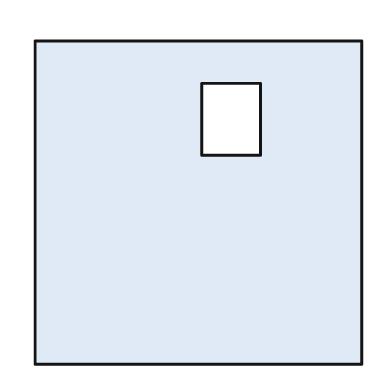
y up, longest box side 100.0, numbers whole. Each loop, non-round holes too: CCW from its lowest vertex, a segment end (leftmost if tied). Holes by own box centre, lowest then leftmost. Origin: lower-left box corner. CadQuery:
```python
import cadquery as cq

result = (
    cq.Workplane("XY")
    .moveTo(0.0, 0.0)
    .lineTo(100.0, 0.0)
    .lineTo(100.0, 99.0)
    .lineTo(0.0, 99.0)
    .close()
    .moveTo(51.0, 64.0)
    .lineTo(69.0, 64.0)
    .lineTo(69.0, 86.0)
    .lineTo(51.0, 86.0)
    .close()
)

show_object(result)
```